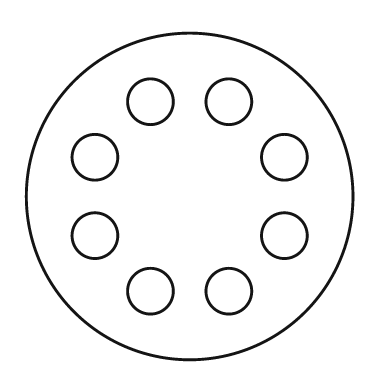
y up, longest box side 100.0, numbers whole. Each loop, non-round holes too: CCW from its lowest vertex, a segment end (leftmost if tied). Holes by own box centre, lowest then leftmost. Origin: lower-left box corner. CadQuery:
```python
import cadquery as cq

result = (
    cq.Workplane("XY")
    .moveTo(50.0, 50.0)
    .circle(50.0)
    .moveTo(38.0, 21.0)
    .circle(7.0)
    .moveTo(62.0, 21.0)
    .circle(7.0)
    .moveTo(21.0, 38.0)
    .circle(7.0)
    .moveTo(79.0, 38.0)
    .circle(7.0)
    .moveTo(21.0, 62.0)
    .circle(7.0)
    .moveTo(79.0, 62.0)
    .circle(7.0)
    .moveTo(38.0, 79.0)
    .circle(7.0)
    .moveTo(62.0, 79.0)
    .circle(7.0)
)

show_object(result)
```